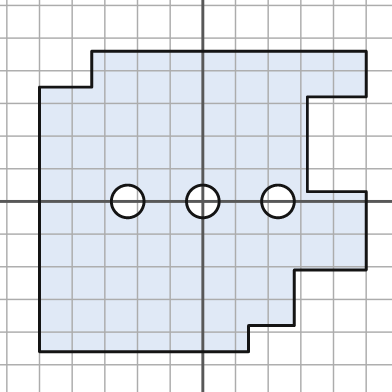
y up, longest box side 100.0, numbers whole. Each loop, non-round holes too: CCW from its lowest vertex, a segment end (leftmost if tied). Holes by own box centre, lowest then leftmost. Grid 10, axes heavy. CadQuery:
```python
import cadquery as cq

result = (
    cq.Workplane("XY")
    .moveTo(-50.0, -46.0)
    .lineTo(14.0, -46.0)
    .lineTo(14.0, -38.0)
    .lineTo(28.0, -38.0)
    .lineTo(28.0, -21.0)
    .lineTo(50.0, -21.0)
    .lineTo(50.0, 3.0)
    .lineTo(32.0, 3.0)
    .lineTo(32.0, 32.0)
    .lineTo(50.0, 32.0)
    .lineTo(50.0, 46.0)
    .lineTo(-34.0, 46.0)
    .lineTo(-34.0, 35.0)
    .lineTo(-50.0, 35.0)
    .close()
    .moveTo(-23.0, 0.0)
    .circle(5.0)
    .moveTo(0.0, 0.0)
    .circle(5.0)
    .moveTo(23.0, 0.0)
    .circle(5.0)
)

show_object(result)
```